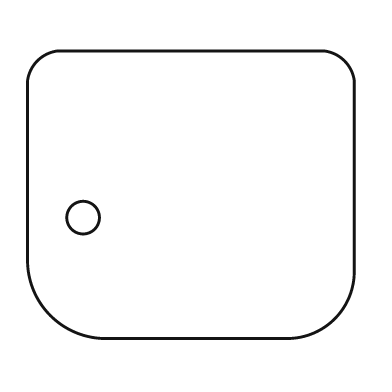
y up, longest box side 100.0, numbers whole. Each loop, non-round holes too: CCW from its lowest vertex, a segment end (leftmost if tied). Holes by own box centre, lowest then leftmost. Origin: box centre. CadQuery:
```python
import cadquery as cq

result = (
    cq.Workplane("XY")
    .moveTo(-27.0, -44.0)
    .lineTo(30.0, -44.0)
    .threePointArc((44.0, -38.0), (50.0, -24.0))
    .lineTo(50.0, 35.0)
    .threePointArc((47.0, 41.0), (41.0, 44.0))
    .lineTo(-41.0, 44.0)
    .threePointArc((-47.0, 41.0), (-50.0, 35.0))
    .lineTo(-50.0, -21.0)
    .threePointArc((-43.0, -37.0), (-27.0, -44.0))
    .close()
    .moveTo(-33.0, -7.0)
    .circle(5.0)
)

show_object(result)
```